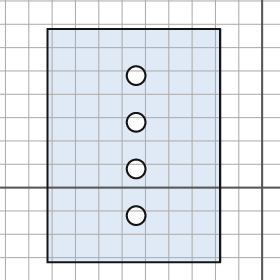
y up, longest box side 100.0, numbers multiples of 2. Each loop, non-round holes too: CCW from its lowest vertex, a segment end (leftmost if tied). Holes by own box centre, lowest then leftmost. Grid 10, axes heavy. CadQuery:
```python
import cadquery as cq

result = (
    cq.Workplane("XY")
    .moveTo(-92.0, -32.0)
    .lineTo(-18.0, -32.0)
    .lineTo(-18.0, 68.0)
    .lineTo(-92.0, 68.0)
    .close()
    .moveTo(-54.0, -12.0)
    .circle(4.0)
    .moveTo(-54.0, 8.0)
    .circle(4.0)
    .moveTo(-54.0, 28.0)
    .circle(4.0)
    .moveTo(-54.0, 48.0)
    .circle(4.0)
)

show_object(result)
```